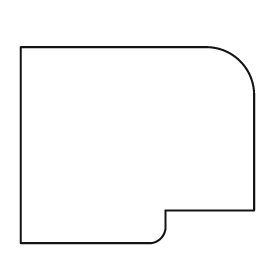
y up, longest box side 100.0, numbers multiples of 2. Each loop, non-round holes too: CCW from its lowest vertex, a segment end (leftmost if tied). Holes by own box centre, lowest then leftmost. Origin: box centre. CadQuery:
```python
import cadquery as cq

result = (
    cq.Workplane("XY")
    .moveTo(-50.0, -42.0)
    .lineTo(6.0, -42.0)
    .threePointArc((10.0, -40.0), (12.0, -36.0))
    .lineTo(12.0, -28.0)
    .lineTo(50.0, -28.0)
    .lineTo(50.0, 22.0)
    .threePointArc((44.0, 36.0), (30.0, 42.0))
    .lineTo(-50.0, 42.0)
    .close()
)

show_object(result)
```